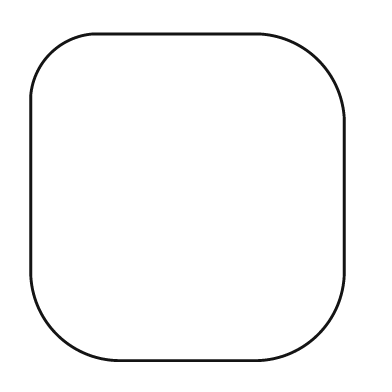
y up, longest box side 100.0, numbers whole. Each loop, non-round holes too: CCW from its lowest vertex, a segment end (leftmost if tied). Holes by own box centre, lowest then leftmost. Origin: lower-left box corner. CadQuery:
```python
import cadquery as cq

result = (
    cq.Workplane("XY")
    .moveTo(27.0, 0.0)
    .lineTo(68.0, 0.0)
    .threePointArc((88.0, 8.0), (96.0, 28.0))
    .lineTo(96.0, 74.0)
    .threePointArc((88.0, 92.0), (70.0, 100.0))
    .lineTo(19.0, 100.0)
    .threePointArc((6.0, 94.0), (0.0, 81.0))
    .lineTo(0.0, 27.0)
    .threePointArc((8.0, 8.0), (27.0, 0.0))
    .close()
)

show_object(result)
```